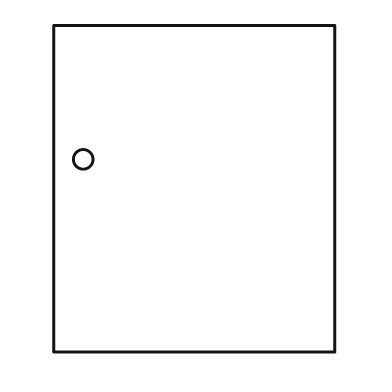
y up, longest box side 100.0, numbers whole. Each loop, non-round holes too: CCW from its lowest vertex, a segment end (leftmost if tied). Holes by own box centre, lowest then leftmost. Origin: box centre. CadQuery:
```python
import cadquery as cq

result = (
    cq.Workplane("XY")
    .moveTo(-43.0, -50.0)
    .lineTo(43.0, -50.0)
    .lineTo(43.0, 50.0)
    .lineTo(-43.0, 50.0)
    .close()
    .moveTo(-34.0, 9.0)
    .circle(3.0)
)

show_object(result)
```